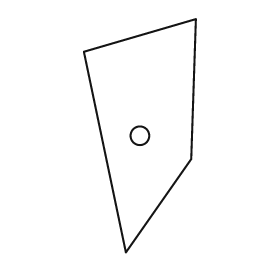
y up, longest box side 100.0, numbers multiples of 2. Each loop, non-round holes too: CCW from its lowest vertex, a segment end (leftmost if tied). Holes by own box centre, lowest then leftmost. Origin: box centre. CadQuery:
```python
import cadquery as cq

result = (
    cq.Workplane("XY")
    .moveTo(-6.0, -50.0)
    .lineTo(22.0, -10.0)
    .lineTo(24.0, 50.0)
    .lineTo(-24.0, 36.0)
    .close()
    .moveTo(0.0, 0.0)
    .circle(4.0)
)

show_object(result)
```